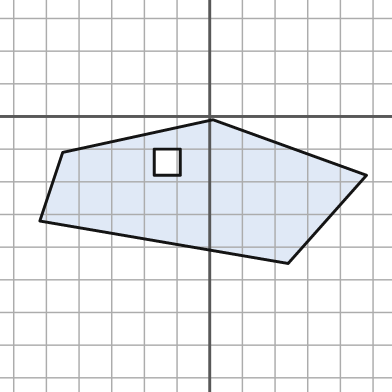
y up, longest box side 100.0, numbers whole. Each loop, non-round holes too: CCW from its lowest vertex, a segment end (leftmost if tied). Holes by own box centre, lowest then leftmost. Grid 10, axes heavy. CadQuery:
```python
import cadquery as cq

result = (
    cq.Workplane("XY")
    .moveTo(24.0, -45.0)
    .lineTo(48.0, -18.0)
    .lineTo(1.0, -1.0)
    .lineTo(-45.0, -11.0)
    .lineTo(-52.0, -32.0)
    .close()
    .moveTo(-17.0, -18.0)
    .lineTo(-9.0, -18.0)
    .lineTo(-9.0, -10.0)
    .lineTo(-17.0, -10.0)
    .close()
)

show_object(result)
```